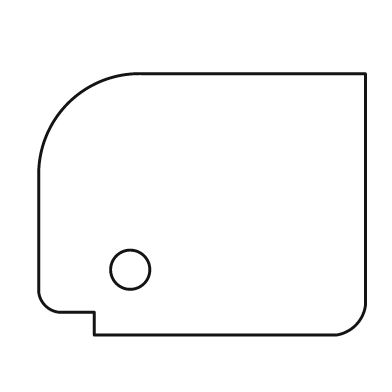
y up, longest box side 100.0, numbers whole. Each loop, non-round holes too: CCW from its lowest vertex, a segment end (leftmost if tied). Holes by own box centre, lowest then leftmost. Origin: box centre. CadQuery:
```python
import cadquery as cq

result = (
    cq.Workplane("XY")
    .moveTo(-33.0, -40.0)
    .lineTo(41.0, -40.0)
    .threePointArc((47.0, -37.0), (50.0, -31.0))
    .lineTo(50.0, 40.0)
    .lineTo(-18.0, 40.0)
    .threePointArc((-41.0, 31.0), (-50.0, 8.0))
    .lineTo(-50.0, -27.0)
    .threePointArc((-48.0, -31.0), (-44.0, -33.0))
    .lineTo(-33.0, -33.0)
    .close()
    .moveTo(-22.0, -20.0)
    .circle(6.0)
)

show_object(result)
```